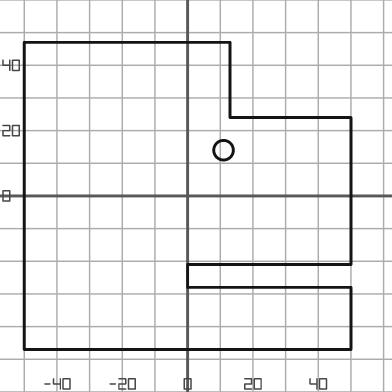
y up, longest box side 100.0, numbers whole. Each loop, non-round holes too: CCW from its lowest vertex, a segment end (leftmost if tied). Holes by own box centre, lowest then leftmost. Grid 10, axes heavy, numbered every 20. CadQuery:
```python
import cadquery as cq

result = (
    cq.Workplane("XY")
    .moveTo(-50.0, -47.0)
    .lineTo(50.0, -47.0)
    .lineTo(50.0, -28.0)
    .lineTo(0.0, -28.0)
    .lineTo(0.0, -21.0)
    .lineTo(50.0, -21.0)
    .lineTo(50.0, 24.0)
    .lineTo(13.0, 24.0)
    .lineTo(13.0, 47.0)
    .lineTo(-50.0, 47.0)
    .close()
    .moveTo(11.0, 14.0)
    .circle(3.0)
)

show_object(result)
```